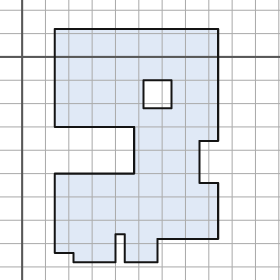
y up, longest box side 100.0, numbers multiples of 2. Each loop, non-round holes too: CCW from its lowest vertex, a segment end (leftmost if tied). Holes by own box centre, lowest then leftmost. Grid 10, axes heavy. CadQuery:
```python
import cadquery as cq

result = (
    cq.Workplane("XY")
    .moveTo(22.0, -88.0)
    .lineTo(40.0, -88.0)
    .lineTo(40.0, -76.0)
    .lineTo(44.0, -76.0)
    .lineTo(44.0, -88.0)
    .lineTo(58.0, -88.0)
    .lineTo(58.0, -78.0)
    .lineTo(84.0, -78.0)
    .lineTo(84.0, -54.0)
    .lineTo(76.0, -54.0)
    .lineTo(76.0, -36.0)
    .lineTo(84.0, -36.0)
    .lineTo(84.0, 12.0)
    .lineTo(14.0, 12.0)
    .lineTo(14.0, -30.0)
    .lineTo(48.0, -30.0)
    .lineTo(48.0, -50.0)
    .lineTo(14.0, -50.0)
    .lineTo(14.0, -84.0)
    .lineTo(22.0, -84.0)
    .close()
    .moveTo(52.0, -22.0)
    .lineTo(64.0, -22.0)
    .lineTo(64.0, -10.0)
    .lineTo(52.0, -10.0)
    .close()
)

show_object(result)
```